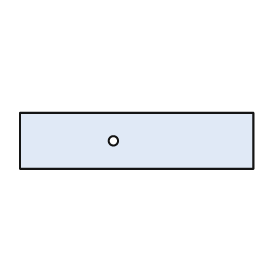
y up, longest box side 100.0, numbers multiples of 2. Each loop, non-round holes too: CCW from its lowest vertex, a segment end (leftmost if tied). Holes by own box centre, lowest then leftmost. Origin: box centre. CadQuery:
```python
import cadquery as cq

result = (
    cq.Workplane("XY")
    .moveTo(-50.0, -12.0)
    .lineTo(50.0, -12.0)
    .lineTo(50.0, 12.0)
    .lineTo(-50.0, 12.0)
    .close()
    .moveTo(-10.0, 0.0)
    .circle(2.0)
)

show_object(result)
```